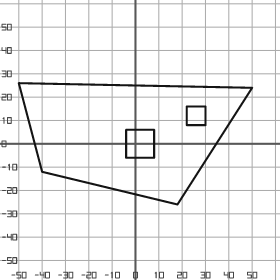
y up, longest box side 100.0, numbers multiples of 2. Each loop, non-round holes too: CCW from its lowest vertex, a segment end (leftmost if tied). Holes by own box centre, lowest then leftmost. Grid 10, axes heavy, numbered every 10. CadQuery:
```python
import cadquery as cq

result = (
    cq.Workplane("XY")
    .moveTo(18.0, -26.0)
    .lineTo(50.0, 24.0)
    .lineTo(-50.0, 26.0)
    .lineTo(-40.0, -12.0)
    .close()
    .moveTo(-4.0, -6.0)
    .lineTo(8.0, -6.0)
    .lineTo(8.0, 6.0)
    .lineTo(-4.0, 6.0)
    .close()
    .moveTo(22.0, 8.0)
    .lineTo(30.0, 8.0)
    .lineTo(30.0, 16.0)
    .lineTo(22.0, 16.0)
    .close()
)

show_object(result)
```